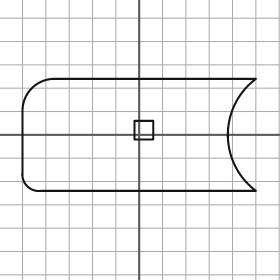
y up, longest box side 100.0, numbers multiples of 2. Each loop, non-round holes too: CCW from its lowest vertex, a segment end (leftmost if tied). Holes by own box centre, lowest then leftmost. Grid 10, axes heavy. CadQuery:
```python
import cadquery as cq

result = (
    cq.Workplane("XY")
    .moveTo(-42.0, -24.0)
    .lineTo(50.0, -24.0)
    .threePointArc((38.0, 0.0), (50.0, 24.0))
    .lineTo(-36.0, 24.0)
    .threePointArc((-46.0, 20.0), (-50.0, 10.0))
    .lineTo(-50.0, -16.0)
    .threePointArc((-48.0, -22.0), (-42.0, -24.0))
    .close()
    .moveTo(-2.0, -2.0)
    .lineTo(6.0, -2.0)
    .lineTo(6.0, 6.0)
    .lineTo(-2.0, 6.0)
    .close()
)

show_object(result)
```